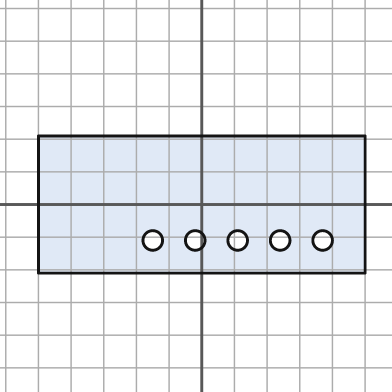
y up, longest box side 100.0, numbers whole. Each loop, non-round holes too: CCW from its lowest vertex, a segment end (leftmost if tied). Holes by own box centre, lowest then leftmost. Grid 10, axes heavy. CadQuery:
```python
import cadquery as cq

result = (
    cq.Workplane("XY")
    .moveTo(-50.0, -21.0)
    .lineTo(50.0, -21.0)
    .lineTo(50.0, 21.0)
    .lineTo(-50.0, 21.0)
    .close()
    .moveTo(-15.0, -11.0)
    .circle(3.0)
    .moveTo(-2.0, -11.0)
    .circle(3.0)
    .moveTo(11.0, -11.0)
    .circle(3.0)
    .moveTo(24.0, -11.0)
    .circle(3.0)
    .moveTo(37.0, -11.0)
    .circle(3.0)
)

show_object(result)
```